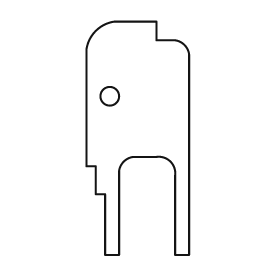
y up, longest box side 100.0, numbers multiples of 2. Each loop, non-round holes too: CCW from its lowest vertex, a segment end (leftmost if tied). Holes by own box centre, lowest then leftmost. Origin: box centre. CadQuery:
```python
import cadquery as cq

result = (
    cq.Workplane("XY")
    .moveTo(-14.0, -50.0)
    .lineTo(-8.0, -50.0)
    .lineTo(-8.0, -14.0)
    .threePointArc((-6.0, -10.0), (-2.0, -8.0))
    .lineTo(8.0, -8.0)
    .threePointArc((14.0, -10.0), (16.0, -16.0))
    .lineTo(16.0, -50.0)
    .lineTo(22.0, -50.0)
    .lineTo(22.0, 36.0)
    .threePointArc((20.0, 40.0), (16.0, 42.0))
    .lineTo(8.0, 42.0)
    .lineTo(8.0, 50.0)
    .lineTo(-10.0, 50.0)
    .threePointArc((-18.0, 46.0), (-22.0, 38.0))
    .lineTo(-22.0, -12.0)
    .lineTo(-18.0, -12.0)
    .lineTo(-18.0, -24.0)
    .lineTo(-14.0, -24.0)
    .close()
    .moveTo(-12.0, 18.0)
    .circle(4.0)
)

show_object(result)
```